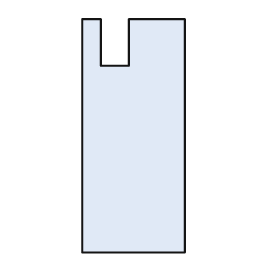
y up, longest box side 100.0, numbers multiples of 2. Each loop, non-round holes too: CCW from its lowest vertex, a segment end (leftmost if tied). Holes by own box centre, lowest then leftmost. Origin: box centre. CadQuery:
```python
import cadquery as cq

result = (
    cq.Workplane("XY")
    .moveTo(-22.0, -50.0)
    .lineTo(22.0, -50.0)
    .lineTo(22.0, 50.0)
    .lineTo(-2.0, 50.0)
    .lineTo(-2.0, 30.0)
    .lineTo(-14.0, 30.0)
    .lineTo(-14.0, 50.0)
    .lineTo(-22.0, 50.0)
    .close()
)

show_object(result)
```